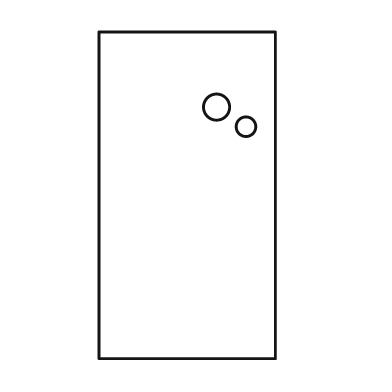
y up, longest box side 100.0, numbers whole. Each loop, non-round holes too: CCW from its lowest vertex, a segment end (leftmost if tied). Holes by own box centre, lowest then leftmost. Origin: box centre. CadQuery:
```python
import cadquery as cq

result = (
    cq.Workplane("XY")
    .moveTo(-27.0, -50.0)
    .lineTo(27.0, -50.0)
    .lineTo(27.0, 50.0)
    .lineTo(-27.0, 50.0)
    .close()
    .moveTo(18.0, 21.0)
    .circle(3.0)
    .moveTo(9.0, 27.0)
    .circle(4.0)
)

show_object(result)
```